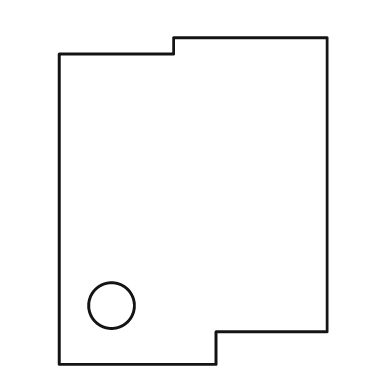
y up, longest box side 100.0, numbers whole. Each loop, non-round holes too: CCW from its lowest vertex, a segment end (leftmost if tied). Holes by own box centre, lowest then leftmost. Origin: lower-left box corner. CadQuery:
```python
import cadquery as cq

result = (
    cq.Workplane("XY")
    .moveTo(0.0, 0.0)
    .lineTo(48.0, 0.0)
    .lineTo(48.0, 10.0)
    .lineTo(82.0, 10.0)
    .lineTo(82.0, 100.0)
    .lineTo(35.0, 100.0)
    .lineTo(35.0, 95.0)
    .lineTo(0.0, 95.0)
    .close()
    .moveTo(16.0, 18.0)
    .circle(7.0)
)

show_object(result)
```